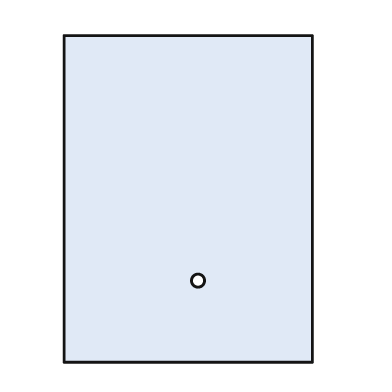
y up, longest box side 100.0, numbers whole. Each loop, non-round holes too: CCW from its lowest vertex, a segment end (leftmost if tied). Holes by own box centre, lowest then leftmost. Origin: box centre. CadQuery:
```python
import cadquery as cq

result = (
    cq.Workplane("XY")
    .moveTo(-38.0, -50.0)
    .lineTo(38.0, -50.0)
    .lineTo(38.0, 50.0)
    .lineTo(-38.0, 50.0)
    .close()
    .moveTo(3.0, -25.0)
    .circle(2.0)
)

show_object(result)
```